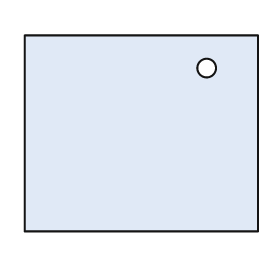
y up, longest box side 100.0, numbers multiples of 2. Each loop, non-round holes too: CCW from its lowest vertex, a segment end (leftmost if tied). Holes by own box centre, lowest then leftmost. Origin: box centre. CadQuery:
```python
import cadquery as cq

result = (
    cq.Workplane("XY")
    .moveTo(-50.0, -42.0)
    .lineTo(50.0, -42.0)
    .lineTo(50.0, 42.0)
    .lineTo(-50.0, 42.0)
    .close()
    .moveTo(28.0, 28.0)
    .circle(4.0)
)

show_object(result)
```